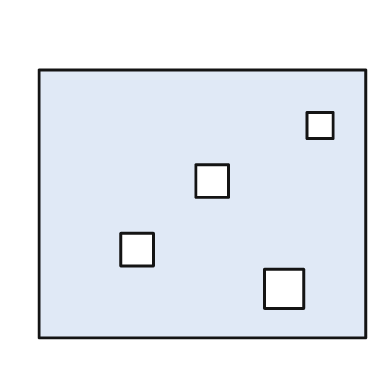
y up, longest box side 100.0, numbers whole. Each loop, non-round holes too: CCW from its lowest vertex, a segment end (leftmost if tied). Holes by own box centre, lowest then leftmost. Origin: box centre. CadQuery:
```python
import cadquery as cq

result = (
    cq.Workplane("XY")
    .moveTo(-50.0, -41.0)
    .lineTo(50.0, -41.0)
    .lineTo(50.0, 41.0)
    .lineTo(-50.0, 41.0)
    .close()
    .moveTo(19.0, -32.0)
    .lineTo(31.0, -32.0)
    .lineTo(31.0, -20.0)
    .lineTo(19.0, -20.0)
    .close()
    .moveTo(-25.0, -19.0)
    .lineTo(-15.0, -19.0)
    .lineTo(-15.0, -9.0)
    .lineTo(-25.0, -9.0)
    .close()
    .moveTo(-2.0, 2.0)
    .lineTo(8.0, 2.0)
    .lineTo(8.0, 12.0)
    .lineTo(-2.0, 12.0)
    .close()
    .moveTo(32.0, 20.0)
    .lineTo(40.0, 20.0)
    .lineTo(40.0, 28.0)
    .lineTo(32.0, 28.0)
    .close()
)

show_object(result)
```